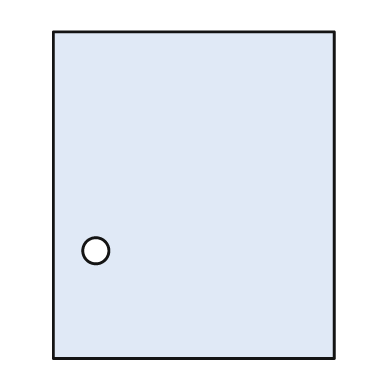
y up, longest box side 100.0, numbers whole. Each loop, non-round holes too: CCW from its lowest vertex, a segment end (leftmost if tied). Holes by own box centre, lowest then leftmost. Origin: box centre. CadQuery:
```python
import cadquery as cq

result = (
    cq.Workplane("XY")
    .moveTo(-43.0, -50.0)
    .lineTo(43.0, -50.0)
    .lineTo(43.0, 50.0)
    .lineTo(-43.0, 50.0)
    .close()
    .moveTo(-30.0, -17.0)
    .circle(4.0)
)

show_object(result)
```